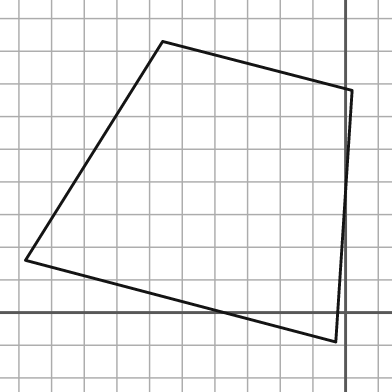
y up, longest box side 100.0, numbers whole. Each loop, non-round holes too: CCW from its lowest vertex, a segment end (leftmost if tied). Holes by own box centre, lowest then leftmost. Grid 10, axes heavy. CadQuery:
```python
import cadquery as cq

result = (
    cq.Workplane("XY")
    .moveTo(-3.0, -9.0)
    .lineTo(2.0, 68.0)
    .lineTo(-56.0, 83.0)
    .lineTo(-98.0, 16.0)
    .close()
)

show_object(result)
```